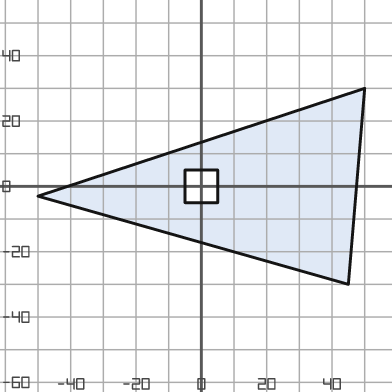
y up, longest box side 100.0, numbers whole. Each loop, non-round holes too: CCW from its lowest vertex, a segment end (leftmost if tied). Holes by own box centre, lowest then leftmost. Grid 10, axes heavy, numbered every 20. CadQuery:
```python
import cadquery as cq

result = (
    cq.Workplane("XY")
    .moveTo(45.0, -30.0)
    .lineTo(50.0, 30.0)
    .lineTo(-50.0, -3.0)
    .close()
    .moveTo(-5.0, -5.0)
    .lineTo(5.0, -5.0)
    .lineTo(5.0, 5.0)
    .lineTo(-5.0, 5.0)
    .close()
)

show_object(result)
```